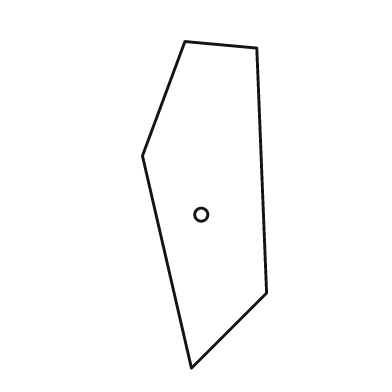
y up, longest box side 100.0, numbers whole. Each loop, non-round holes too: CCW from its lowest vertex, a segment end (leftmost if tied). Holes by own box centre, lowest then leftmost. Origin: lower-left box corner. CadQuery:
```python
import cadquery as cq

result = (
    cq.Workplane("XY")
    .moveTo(15.0, 0.0)
    .lineTo(38.0, 23.0)
    .lineTo(35.0, 98.0)
    .lineTo(13.0, 100.0)
    .lineTo(0.0, 65.0)
    .close()
    .moveTo(18.0, 47.0)
    .circle(2.0)
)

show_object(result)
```